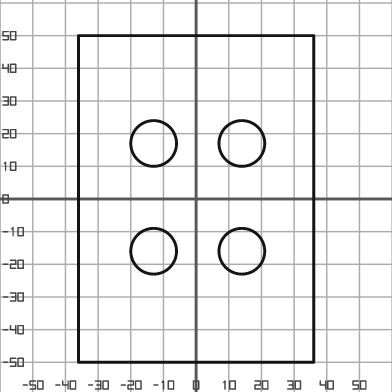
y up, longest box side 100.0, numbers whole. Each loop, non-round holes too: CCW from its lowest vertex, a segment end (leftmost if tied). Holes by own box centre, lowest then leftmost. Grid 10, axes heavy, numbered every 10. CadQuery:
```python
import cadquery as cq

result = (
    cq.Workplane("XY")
    .moveTo(-36.0, -50.0)
    .lineTo(36.0, -50.0)
    .lineTo(36.0, 50.0)
    .lineTo(-36.0, 50.0)
    .close()
    .moveTo(-13.0, -16.0)
    .circle(7.0)
    .moveTo(14.0, -16.0)
    .circle(7.0)
    .moveTo(-13.0, 17.0)
    .circle(7.0)
    .moveTo(14.0, 17.0)
    .circle(7.0)
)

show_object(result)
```